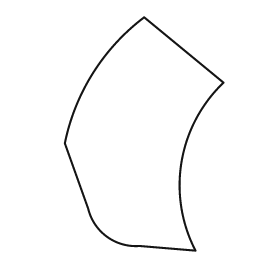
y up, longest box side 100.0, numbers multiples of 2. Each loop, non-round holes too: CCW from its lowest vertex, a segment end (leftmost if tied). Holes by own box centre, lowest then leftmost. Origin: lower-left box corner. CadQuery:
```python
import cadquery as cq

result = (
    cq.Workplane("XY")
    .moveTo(56.0, 0.0)
    .threePointArc((50.0, 38.0), (68.0, 72.0))
    .lineTo(34.0, 100.0)
    .threePointArc((12.0, 76.0), (0.0, 46.0))
    .lineTo(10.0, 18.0)
    .threePointArc((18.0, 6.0), (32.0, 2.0))
    .close()
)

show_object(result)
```